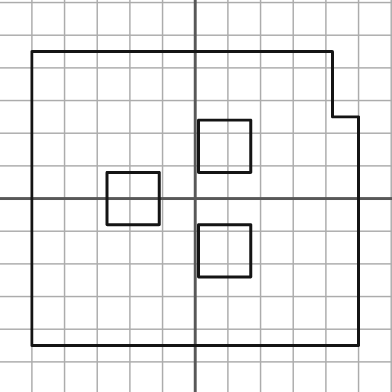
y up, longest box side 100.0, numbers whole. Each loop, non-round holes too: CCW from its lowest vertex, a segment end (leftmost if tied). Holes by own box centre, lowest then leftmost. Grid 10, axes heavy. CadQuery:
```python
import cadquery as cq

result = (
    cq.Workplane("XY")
    .moveTo(-50.0, -45.0)
    .lineTo(50.0, -45.0)
    .lineTo(50.0, 25.0)
    .lineTo(42.0, 25.0)
    .lineTo(42.0, 45.0)
    .lineTo(-50.0, 45.0)
    .close()
    .moveTo(1.0, -24.0)
    .lineTo(17.0, -24.0)
    .lineTo(17.0, -8.0)
    .lineTo(1.0, -8.0)
    .close()
    .moveTo(-27.0, -8.0)
    .lineTo(-11.0, -8.0)
    .lineTo(-11.0, 8.0)
    .lineTo(-27.0, 8.0)
    .close()
    .moveTo(1.0, 8.0)
    .lineTo(17.0, 8.0)
    .lineTo(17.0, 24.0)
    .lineTo(1.0, 24.0)
    .close()
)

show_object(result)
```